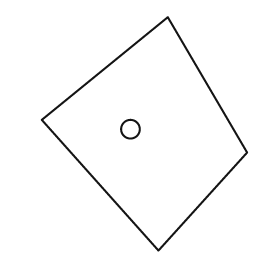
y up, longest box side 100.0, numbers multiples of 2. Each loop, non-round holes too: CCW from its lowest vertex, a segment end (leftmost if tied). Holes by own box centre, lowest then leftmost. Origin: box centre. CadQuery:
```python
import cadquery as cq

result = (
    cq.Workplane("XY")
    .moveTo(6.0, -50.0)
    .lineTo(44.0, -8.0)
    .lineTo(10.0, 50.0)
    .lineTo(-44.0, 6.0)
    .close()
    .moveTo(-6.0, 2.0)
    .circle(4.0)
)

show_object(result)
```